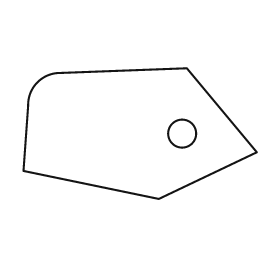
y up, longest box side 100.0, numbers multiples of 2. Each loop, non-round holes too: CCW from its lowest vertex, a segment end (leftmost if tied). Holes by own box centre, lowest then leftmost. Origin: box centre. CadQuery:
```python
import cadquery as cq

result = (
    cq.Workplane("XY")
    .moveTo(8.0, -28.0)
    .lineTo(50.0, -8.0)
    .lineTo(20.0, 28.0)
    .lineTo(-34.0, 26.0)
    .threePointArc((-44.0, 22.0), (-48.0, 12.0))
    .lineTo(-50.0, -16.0)
    .close()
    .moveTo(18.0, 0.0)
    .circle(6.0)
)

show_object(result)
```